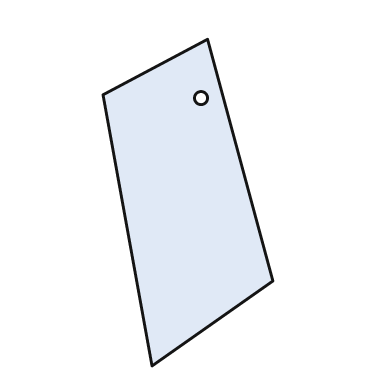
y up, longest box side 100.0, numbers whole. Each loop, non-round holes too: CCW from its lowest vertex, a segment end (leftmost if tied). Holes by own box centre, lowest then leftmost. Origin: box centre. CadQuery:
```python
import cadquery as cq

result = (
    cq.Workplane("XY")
    .moveTo(-11.0, -50.0)
    .lineTo(26.0, -24.0)
    .lineTo(6.0, 50.0)
    .lineTo(-26.0, 33.0)
    .close()
    .moveTo(4.0, 32.0)
    .circle(2.0)
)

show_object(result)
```